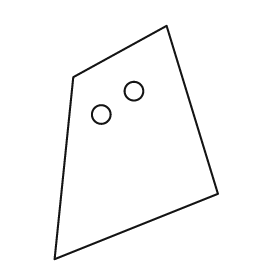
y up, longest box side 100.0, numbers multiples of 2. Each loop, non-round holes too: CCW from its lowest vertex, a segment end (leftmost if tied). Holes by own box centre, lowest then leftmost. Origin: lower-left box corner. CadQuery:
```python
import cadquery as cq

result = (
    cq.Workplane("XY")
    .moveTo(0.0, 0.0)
    .lineTo(70.0, 28.0)
    .lineTo(48.0, 100.0)
    .lineTo(8.0, 78.0)
    .close()
    .moveTo(20.0, 62.0)
    .circle(4.0)
    .moveTo(34.0, 72.0)
    .circle(4.0)
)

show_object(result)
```